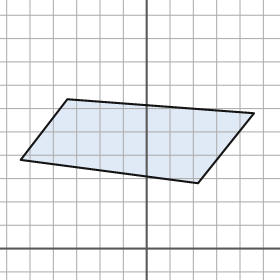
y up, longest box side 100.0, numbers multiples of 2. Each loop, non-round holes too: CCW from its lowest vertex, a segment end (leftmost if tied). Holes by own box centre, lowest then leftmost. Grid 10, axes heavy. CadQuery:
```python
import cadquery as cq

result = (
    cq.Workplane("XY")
    .moveTo(22.0, 28.0)
    .lineTo(46.0, 58.0)
    .lineTo(-34.0, 64.0)
    .lineTo(-54.0, 38.0)
    .close()
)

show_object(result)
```